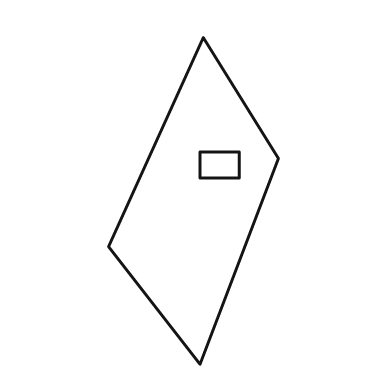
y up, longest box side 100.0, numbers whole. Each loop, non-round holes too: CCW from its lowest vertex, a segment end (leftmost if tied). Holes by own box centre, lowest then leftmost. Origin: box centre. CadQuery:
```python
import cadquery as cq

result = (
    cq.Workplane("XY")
    .moveTo(2.0, -50.0)
    .lineTo(26.0, 13.0)
    .lineTo(3.0, 50.0)
    .lineTo(-26.0, -14.0)
    .close()
    .moveTo(2.0, 7.0)
    .lineTo(14.0, 7.0)
    .lineTo(14.0, 15.0)
    .lineTo(2.0, 15.0)
    .close()
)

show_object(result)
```